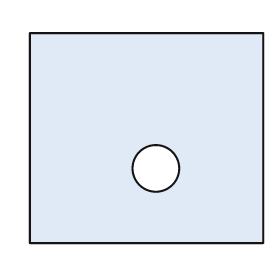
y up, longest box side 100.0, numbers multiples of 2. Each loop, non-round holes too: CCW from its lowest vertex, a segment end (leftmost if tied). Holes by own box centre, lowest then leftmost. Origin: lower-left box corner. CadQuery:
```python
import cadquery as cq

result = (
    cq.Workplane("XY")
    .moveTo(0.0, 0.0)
    .lineTo(100.0, 0.0)
    .lineTo(100.0, 90.0)
    .lineTo(0.0, 90.0)
    .close()
    .moveTo(54.0, 32.0)
    .circle(10.0)
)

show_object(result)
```